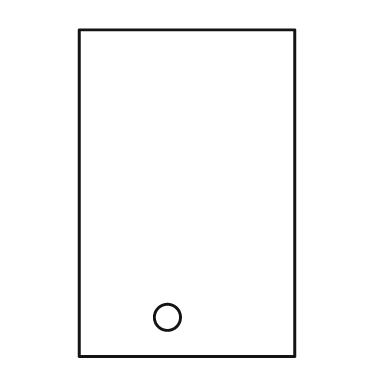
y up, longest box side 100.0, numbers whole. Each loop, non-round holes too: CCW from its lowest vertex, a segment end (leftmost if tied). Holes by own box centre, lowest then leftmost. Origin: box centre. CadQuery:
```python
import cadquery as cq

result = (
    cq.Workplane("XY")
    .moveTo(-33.0, -50.0)
    .lineTo(33.0, -50.0)
    .lineTo(33.0, 50.0)
    .lineTo(-33.0, 50.0)
    .close()
    .moveTo(-6.0, -38.0)
    .circle(4.0)
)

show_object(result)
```